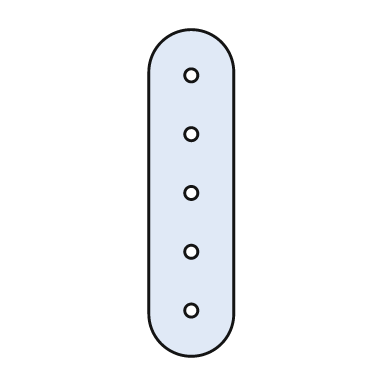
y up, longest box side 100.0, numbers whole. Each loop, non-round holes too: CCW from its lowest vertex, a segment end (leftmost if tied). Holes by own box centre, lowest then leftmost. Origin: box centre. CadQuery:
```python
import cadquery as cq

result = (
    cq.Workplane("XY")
    .moveTo(-13.0, -37.0)
    .threePointArc((0.0, -50.0), (13.0, -37.0))
    .lineTo(13.0, 37.0)
    .threePointArc((0.0, 50.0), (-13.0, 37.0))
    .close()
    .moveTo(0.0, -36.0)
    .circle(2.0)
    .moveTo(0.0, -18.0)
    .circle(2.0)
    .moveTo(0.0, 0.0)
    .circle(2.0)
    .moveTo(0.0, 18.0)
    .circle(2.0)
    .moveTo(0.0, 36.0)
    .circle(2.0)
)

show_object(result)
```